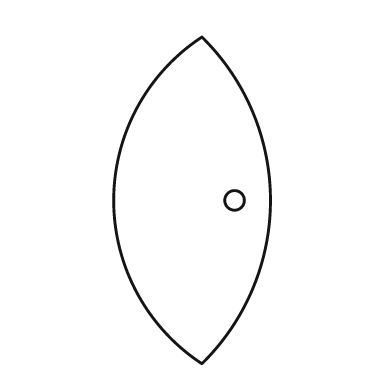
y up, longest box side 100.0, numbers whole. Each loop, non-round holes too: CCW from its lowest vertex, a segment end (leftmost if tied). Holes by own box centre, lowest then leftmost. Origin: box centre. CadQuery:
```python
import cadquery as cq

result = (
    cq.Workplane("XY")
    .moveTo(3.0, -50.0)
    .threePointArc((24.0, 0.0), (3.0, 50.0))
    .threePointArc((-24.0, 0.0), (3.0, -50.0))
    .close()
    .moveTo(13.0, 0.0)
    .circle(3.0)
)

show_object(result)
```